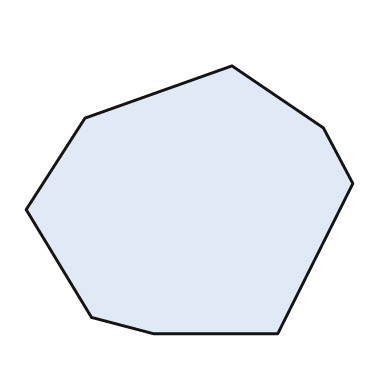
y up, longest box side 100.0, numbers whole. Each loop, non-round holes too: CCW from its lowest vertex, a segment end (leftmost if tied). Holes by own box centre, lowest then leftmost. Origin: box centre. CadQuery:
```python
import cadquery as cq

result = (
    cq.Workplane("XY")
    .moveTo(-11.0, -41.0)
    .lineTo(27.0, -41.0)
    .lineTo(50.0, 5.0)
    .lineTo(41.0, 22.0)
    .lineTo(13.0, 41.0)
    .lineTo(-32.0, 25.0)
    .lineTo(-50.0, -3.0)
    .lineTo(-30.0, -36.0)
    .close()
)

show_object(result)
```